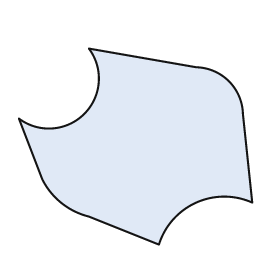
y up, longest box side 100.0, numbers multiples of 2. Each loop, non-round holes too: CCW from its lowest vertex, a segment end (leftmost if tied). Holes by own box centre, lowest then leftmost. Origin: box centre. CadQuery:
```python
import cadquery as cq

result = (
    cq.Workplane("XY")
    .moveTo(10.0, -42.0)
    .threePointArc((26.0, -24.0), (50.0, -24.0))
    .lineTo(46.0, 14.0)
    .threePointArc((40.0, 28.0), (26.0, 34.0))
    .lineTo(-20.0, 42.0)
    .threePointArc((-22.0, 14.0), (-50.0, 12.0))
    .lineTo(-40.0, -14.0)
    .threePointArc((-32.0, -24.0), (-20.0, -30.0))
    .close()
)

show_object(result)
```